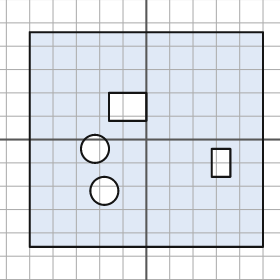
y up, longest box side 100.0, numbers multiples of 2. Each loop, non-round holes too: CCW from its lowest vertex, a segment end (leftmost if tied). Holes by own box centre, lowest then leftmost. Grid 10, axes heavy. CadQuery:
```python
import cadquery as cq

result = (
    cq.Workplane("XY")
    .moveTo(-50.0, -46.0)
    .lineTo(50.0, -46.0)
    .lineTo(50.0, 46.0)
    .lineTo(-50.0, 46.0)
    .close()
    .moveTo(-18.0, -22.0)
    .circle(6.0)
    .moveTo(28.0, -16.0)
    .lineTo(36.0, -16.0)
    .lineTo(36.0, -4.0)
    .lineTo(28.0, -4.0)
    .close()
    .moveTo(-22.0, -4.0)
    .circle(6.0)
    .moveTo(-16.0, 8.0)
    .lineTo(0.0, 8.0)
    .lineTo(0.0, 20.0)
    .lineTo(-16.0, 20.0)
    .close()
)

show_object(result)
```